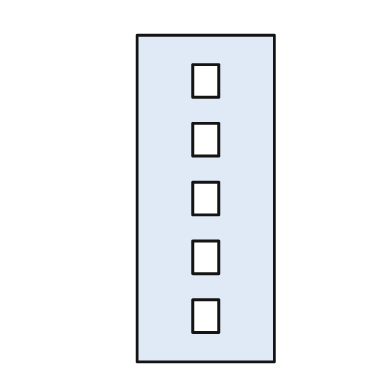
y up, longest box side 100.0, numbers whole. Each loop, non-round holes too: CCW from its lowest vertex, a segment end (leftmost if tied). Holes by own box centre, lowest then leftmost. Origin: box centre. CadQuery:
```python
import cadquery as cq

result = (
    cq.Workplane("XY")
    .moveTo(-21.0, -50.0)
    .lineTo(21.0, -50.0)
    .lineTo(21.0, 50.0)
    .lineTo(-21.0, 50.0)
    .close()
    .moveTo(-4.0, -41.0)
    .lineTo(4.0, -41.0)
    .lineTo(4.0, -31.0)
    .lineTo(-4.0, -31.0)
    .close()
    .moveTo(-4.0, -23.0)
    .lineTo(4.0, -23.0)
    .lineTo(4.0, -13.0)
    .lineTo(-4.0, -13.0)
    .close()
    .moveTo(-4.0, -5.0)
    .lineTo(4.0, -5.0)
    .lineTo(4.0, 5.0)
    .lineTo(-4.0, 5.0)
    .close()
    .moveTo(-4.0, 13.0)
    .lineTo(4.0, 13.0)
    .lineTo(4.0, 23.0)
    .lineTo(-4.0, 23.0)
    .close()
    .moveTo(-4.0, 31.0)
    .lineTo(4.0, 31.0)
    .lineTo(4.0, 41.0)
    .lineTo(-4.0, 41.0)
    .close()
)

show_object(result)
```